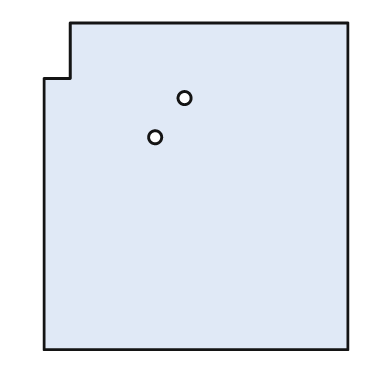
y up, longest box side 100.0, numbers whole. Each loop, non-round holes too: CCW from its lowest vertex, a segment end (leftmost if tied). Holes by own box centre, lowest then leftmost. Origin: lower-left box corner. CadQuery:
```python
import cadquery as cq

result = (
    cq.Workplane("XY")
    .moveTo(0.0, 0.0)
    .lineTo(93.0, 0.0)
    .lineTo(93.0, 100.0)
    .lineTo(8.0, 100.0)
    .lineTo(8.0, 83.0)
    .lineTo(0.0, 83.0)
    .close()
    .moveTo(34.0, 65.0)
    .circle(2.0)
    .moveTo(43.0, 77.0)
    .circle(2.0)
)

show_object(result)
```